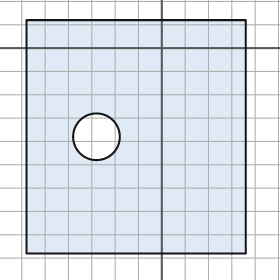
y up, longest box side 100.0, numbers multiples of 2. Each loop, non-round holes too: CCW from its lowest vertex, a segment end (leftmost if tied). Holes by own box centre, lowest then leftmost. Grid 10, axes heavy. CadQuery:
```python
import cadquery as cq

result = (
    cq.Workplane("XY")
    .moveTo(-58.0, -88.0)
    .lineTo(36.0, -88.0)
    .lineTo(36.0, 12.0)
    .lineTo(-58.0, 12.0)
    .close()
    .moveTo(-28.0, -38.0)
    .circle(10.0)
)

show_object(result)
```